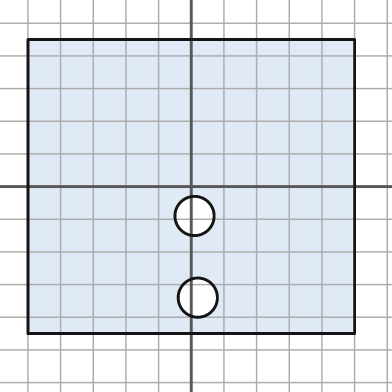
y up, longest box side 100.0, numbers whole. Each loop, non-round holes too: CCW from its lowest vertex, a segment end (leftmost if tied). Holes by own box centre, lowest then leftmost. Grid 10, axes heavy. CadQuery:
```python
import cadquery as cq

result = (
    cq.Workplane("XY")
    .moveTo(-50.0, -45.0)
    .lineTo(50.0, -45.0)
    .lineTo(50.0, 45.0)
    .lineTo(-50.0, 45.0)
    .close()
    .moveTo(2.0, -34.0)
    .circle(6.0)
    .moveTo(1.0, -9.0)
    .circle(6.0)
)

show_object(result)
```